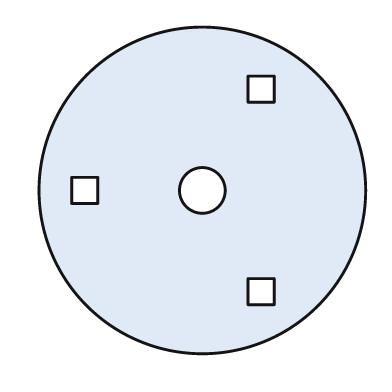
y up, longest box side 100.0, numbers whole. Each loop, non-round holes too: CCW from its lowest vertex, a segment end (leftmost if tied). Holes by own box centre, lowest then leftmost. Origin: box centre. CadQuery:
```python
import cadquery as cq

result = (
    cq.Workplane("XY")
    .moveTo(0.0, 0.0)
    .circle(50.0)
    .moveTo(14.0, -35.0)
    .lineTo(22.0, -35.0)
    .lineTo(22.0, -27.0)
    .lineTo(14.0, -27.0)
    .close()
    .moveTo(-40.0, -4.0)
    .lineTo(-32.0, -4.0)
    .lineTo(-32.0, 4.0)
    .lineTo(-40.0, 4.0)
    .close()
    .moveTo(0.0, 0.0)
    .circle(7.0)
    .moveTo(14.0, 27.0)
    .lineTo(22.0, 27.0)
    .lineTo(22.0, 35.0)
    .lineTo(14.0, 35.0)
    .close()
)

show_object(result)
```